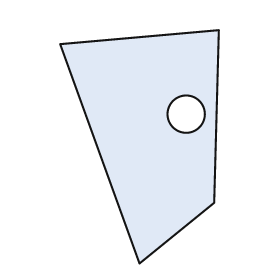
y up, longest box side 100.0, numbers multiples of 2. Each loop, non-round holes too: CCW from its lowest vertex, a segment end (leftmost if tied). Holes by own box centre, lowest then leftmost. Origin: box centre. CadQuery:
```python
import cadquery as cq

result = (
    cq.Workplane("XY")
    .moveTo(0.0, -50.0)
    .lineTo(32.0, -24.0)
    .lineTo(34.0, 50.0)
    .lineTo(-34.0, 44.0)
    .close()
    .moveTo(20.0, 14.0)
    .circle(8.0)
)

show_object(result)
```